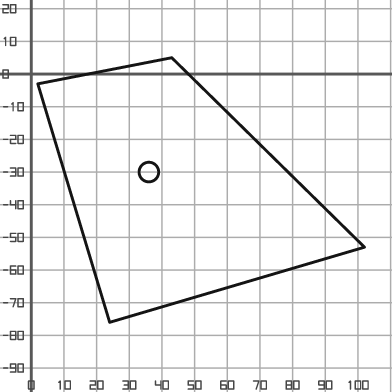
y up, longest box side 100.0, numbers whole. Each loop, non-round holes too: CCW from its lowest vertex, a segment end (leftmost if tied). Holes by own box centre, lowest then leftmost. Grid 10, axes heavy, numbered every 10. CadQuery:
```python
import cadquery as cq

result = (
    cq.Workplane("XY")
    .moveTo(24.0, -76.0)
    .lineTo(102.0, -53.0)
    .lineTo(43.0, 5.0)
    .lineTo(2.0, -3.0)
    .close()
    .moveTo(36.0, -30.0)
    .circle(3.0)
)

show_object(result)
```